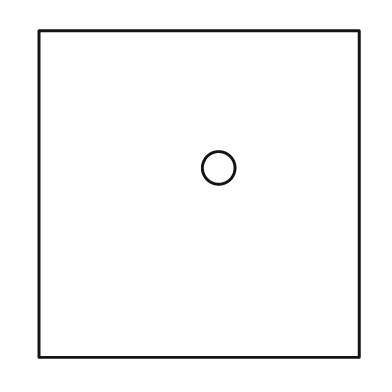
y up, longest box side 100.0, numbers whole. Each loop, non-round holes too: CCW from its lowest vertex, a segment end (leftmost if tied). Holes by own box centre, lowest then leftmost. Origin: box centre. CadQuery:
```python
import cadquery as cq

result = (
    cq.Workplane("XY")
    .moveTo(-49.0, -50.0)
    .lineTo(49.0, -50.0)
    .lineTo(49.0, 50.0)
    .lineTo(-49.0, 50.0)
    .close()
    .moveTo(6.0, 8.0)
    .circle(5.0)
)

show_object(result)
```